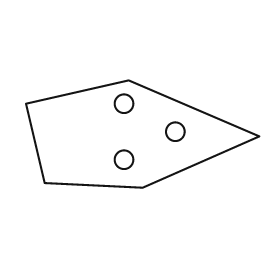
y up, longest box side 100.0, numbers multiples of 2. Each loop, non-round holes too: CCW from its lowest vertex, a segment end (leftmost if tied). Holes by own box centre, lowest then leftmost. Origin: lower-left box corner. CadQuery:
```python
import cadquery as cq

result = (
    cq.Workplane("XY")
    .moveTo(50.0, 0.0)
    .lineTo(100.0, 22.0)
    .lineTo(44.0, 46.0)
    .lineTo(0.0, 36.0)
    .lineTo(8.0, 2.0)
    .close()
    .moveTo(42.0, 12.0)
    .circle(4.0)
    .moveTo(64.0, 24.0)
    .circle(4.0)
    .moveTo(42.0, 36.0)
    .circle(4.0)
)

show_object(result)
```